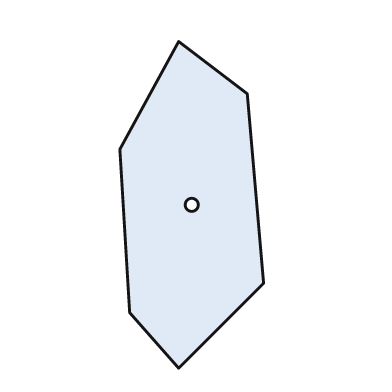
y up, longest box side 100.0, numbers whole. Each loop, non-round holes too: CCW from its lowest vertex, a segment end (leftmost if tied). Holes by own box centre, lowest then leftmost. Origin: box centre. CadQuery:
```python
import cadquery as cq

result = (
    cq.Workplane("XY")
    .moveTo(-4.0, -50.0)
    .lineTo(22.0, -24.0)
    .lineTo(17.0, 34.0)
    .lineTo(-4.0, 50.0)
    .lineTo(-22.0, 17.0)
    .lineTo(-19.0, -33.0)
    .close()
    .moveTo(0.0, 0.0)
    .circle(2.0)
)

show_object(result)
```